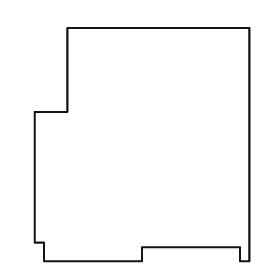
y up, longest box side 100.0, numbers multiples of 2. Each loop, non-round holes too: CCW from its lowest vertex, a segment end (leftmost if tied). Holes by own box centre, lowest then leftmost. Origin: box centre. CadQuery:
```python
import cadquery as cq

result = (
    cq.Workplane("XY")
    .moveTo(-42.0, -50.0)
    .lineTo(0.0, -50.0)
    .lineTo(0.0, -44.0)
    .lineTo(42.0, -44.0)
    .lineTo(42.0, -50.0)
    .lineTo(46.0, -50.0)
    .lineTo(46.0, 50.0)
    .lineTo(-32.0, 50.0)
    .lineTo(-32.0, 14.0)
    .lineTo(-46.0, 14.0)
    .lineTo(-46.0, -42.0)
    .lineTo(-42.0, -42.0)
    .close()
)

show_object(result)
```